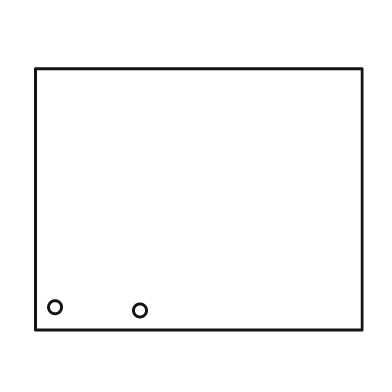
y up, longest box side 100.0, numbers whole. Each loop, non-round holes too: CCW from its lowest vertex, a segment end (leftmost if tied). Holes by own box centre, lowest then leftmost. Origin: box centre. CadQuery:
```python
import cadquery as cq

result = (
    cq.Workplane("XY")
    .moveTo(-50.0, -40.0)
    .lineTo(50.0, -40.0)
    .lineTo(50.0, 40.0)
    .lineTo(-50.0, 40.0)
    .close()
    .moveTo(-18.0, -34.0)
    .circle(2.0)
    .moveTo(-44.0, -33.0)
    .circle(2.0)
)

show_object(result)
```